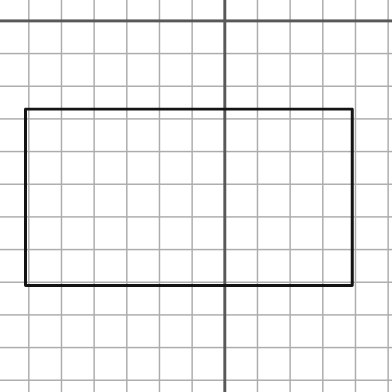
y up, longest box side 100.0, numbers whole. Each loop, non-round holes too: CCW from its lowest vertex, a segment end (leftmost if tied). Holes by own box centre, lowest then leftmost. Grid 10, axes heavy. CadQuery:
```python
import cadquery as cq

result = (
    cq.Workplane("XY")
    .moveTo(-61.0, -81.0)
    .lineTo(39.0, -81.0)
    .lineTo(39.0, -27.0)
    .lineTo(-61.0, -27.0)
    .close()
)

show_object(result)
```